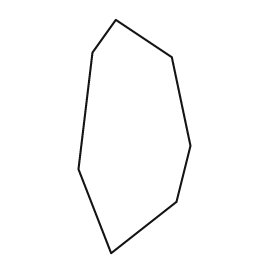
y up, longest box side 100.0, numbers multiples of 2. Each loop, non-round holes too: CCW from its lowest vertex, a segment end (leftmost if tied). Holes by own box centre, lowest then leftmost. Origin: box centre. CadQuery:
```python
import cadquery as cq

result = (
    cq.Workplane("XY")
    .moveTo(-10.0, -50.0)
    .lineTo(18.0, -28.0)
    .lineTo(24.0, -4.0)
    .lineTo(16.0, 34.0)
    .lineTo(-8.0, 50.0)
    .lineTo(-18.0, 36.0)
    .lineTo(-24.0, -14.0)
    .close()
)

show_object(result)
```